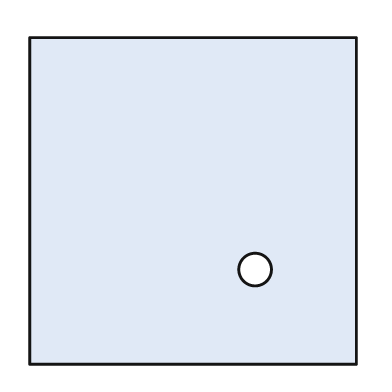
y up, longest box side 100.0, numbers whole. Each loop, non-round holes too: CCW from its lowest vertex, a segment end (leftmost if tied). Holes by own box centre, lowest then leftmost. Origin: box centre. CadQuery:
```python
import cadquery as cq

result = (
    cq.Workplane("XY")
    .moveTo(-50.0, -50.0)
    .lineTo(50.0, -50.0)
    .lineTo(50.0, 50.0)
    .lineTo(-50.0, 50.0)
    .close()
    .moveTo(19.0, -21.0)
    .circle(5.0)
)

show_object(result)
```